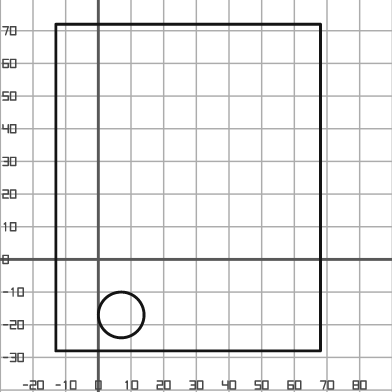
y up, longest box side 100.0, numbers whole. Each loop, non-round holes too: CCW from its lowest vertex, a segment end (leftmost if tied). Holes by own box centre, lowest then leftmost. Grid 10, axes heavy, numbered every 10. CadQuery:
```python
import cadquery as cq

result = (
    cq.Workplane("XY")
    .moveTo(-13.0, -28.0)
    .lineTo(68.0, -28.0)
    .lineTo(68.0, 72.0)
    .lineTo(-13.0, 72.0)
    .close()
    .moveTo(7.0, -17.0)
    .circle(7.0)
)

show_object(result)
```